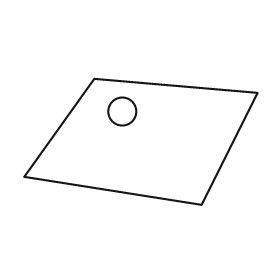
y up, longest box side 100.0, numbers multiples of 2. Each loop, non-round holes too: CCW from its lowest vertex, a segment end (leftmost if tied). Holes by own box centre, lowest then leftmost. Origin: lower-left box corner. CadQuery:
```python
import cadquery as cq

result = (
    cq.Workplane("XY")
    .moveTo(76.0, 0.0)
    .lineTo(100.0, 48.0)
    .lineTo(30.0, 54.0)
    .lineTo(0.0, 12.0)
    .close()
    .moveTo(42.0, 40.0)
    .circle(6.0)
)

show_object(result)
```